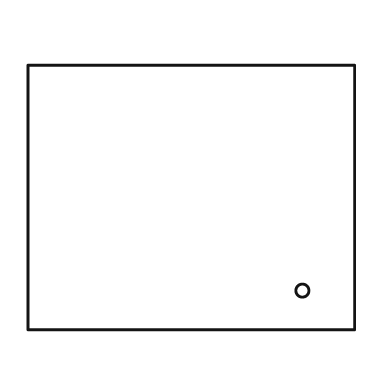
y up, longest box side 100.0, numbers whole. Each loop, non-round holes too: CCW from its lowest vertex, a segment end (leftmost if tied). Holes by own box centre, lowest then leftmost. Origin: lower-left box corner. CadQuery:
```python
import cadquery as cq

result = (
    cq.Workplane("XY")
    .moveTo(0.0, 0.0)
    .lineTo(100.0, 0.0)
    .lineTo(100.0, 81.0)
    .lineTo(0.0, 81.0)
    .close()
    .moveTo(84.0, 12.0)
    .circle(2.0)
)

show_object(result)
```